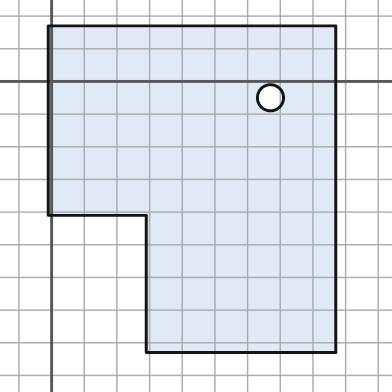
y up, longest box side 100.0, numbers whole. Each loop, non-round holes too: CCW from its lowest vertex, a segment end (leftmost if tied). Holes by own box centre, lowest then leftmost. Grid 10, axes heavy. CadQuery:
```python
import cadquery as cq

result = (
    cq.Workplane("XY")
    .moveTo(29.0, -83.0)
    .lineTo(87.0, -83.0)
    .lineTo(87.0, 17.0)
    .lineTo(-1.0, 17.0)
    .lineTo(-1.0, -41.0)
    .lineTo(29.0, -41.0)
    .close()
    .moveTo(67.0, -5.0)
    .circle(4.0)
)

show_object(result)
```